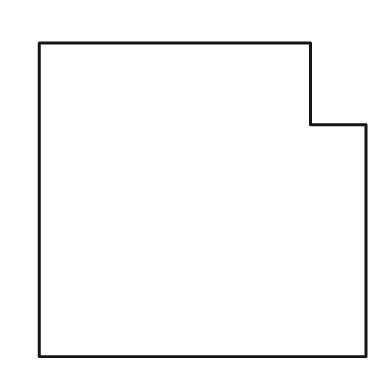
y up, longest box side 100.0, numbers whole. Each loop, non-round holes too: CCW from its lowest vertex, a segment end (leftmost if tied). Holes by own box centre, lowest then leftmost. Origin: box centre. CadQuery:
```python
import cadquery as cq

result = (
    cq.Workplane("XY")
    .moveTo(-50.0, -48.0)
    .lineTo(50.0, -48.0)
    .lineTo(50.0, 23.0)
    .lineTo(33.0, 23.0)
    .lineTo(33.0, 48.0)
    .lineTo(-50.0, 48.0)
    .close()
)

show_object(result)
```